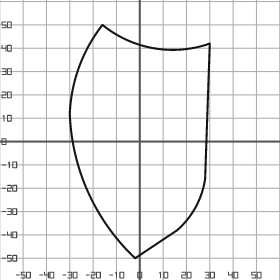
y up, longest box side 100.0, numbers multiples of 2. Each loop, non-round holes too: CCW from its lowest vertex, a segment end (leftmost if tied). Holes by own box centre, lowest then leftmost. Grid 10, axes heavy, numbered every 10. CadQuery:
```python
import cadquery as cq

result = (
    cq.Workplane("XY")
    .moveTo(-2.0, -50.0)
    .lineTo(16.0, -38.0)
    .threePointArc((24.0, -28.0), (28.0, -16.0))
    .lineTo(30.0, 42.0)
    .threePointArc((6.0, 40.0), (-16.0, 50.0))
    .threePointArc((-26.0, 32.0), (-30.0, 12.0))
    .threePointArc((-22.0, -22.0), (-2.0, -50.0))
    .close()
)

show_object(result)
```